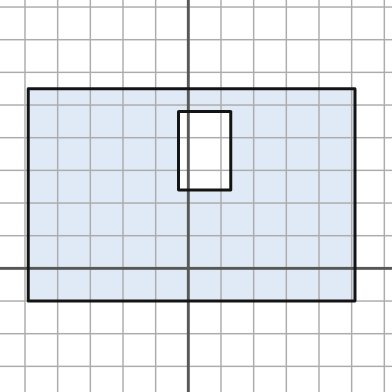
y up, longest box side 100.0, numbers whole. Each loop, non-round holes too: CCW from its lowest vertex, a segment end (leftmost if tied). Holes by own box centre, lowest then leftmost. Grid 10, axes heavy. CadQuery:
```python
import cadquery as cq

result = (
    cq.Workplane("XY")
    .moveTo(-49.0, -10.0)
    .lineTo(51.0, -10.0)
    .lineTo(51.0, 55.0)
    .lineTo(-49.0, 55.0)
    .close()
    .moveTo(-3.0, 24.0)
    .lineTo(13.0, 24.0)
    .lineTo(13.0, 48.0)
    .lineTo(-3.0, 48.0)
    .close()
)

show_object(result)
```